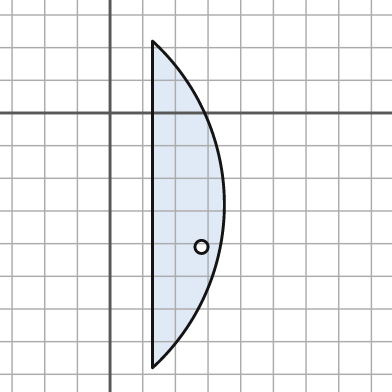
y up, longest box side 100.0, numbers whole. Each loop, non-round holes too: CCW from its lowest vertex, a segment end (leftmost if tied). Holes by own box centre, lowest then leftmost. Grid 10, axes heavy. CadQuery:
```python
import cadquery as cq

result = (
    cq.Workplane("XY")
    .moveTo(13.0, -78.0)
    .threePointArc((35.0, -28.0), (13.0, 22.0))
    .close()
    .moveTo(28.0, -41.0)
    .circle(2.0)
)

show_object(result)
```